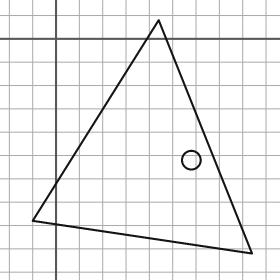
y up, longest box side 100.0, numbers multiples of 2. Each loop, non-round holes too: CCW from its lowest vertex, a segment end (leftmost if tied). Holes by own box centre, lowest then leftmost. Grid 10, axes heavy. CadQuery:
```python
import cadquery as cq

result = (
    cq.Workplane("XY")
    .moveTo(84.0, -92.0)
    .lineTo(44.0, 8.0)
    .lineTo(-10.0, -78.0)
    .close()
    .moveTo(58.0, -52.0)
    .circle(4.0)
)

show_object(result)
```